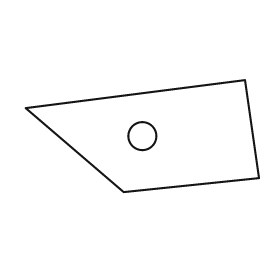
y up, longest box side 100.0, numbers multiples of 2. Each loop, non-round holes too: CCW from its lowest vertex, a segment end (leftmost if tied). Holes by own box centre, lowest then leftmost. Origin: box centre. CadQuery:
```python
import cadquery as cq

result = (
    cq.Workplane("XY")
    .moveTo(-8.0, -24.0)
    .lineTo(50.0, -18.0)
    .lineTo(44.0, 24.0)
    .lineTo(-50.0, 12.0)
    .close()
    .moveTo(0.0, 0.0)
    .circle(6.0)
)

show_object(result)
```